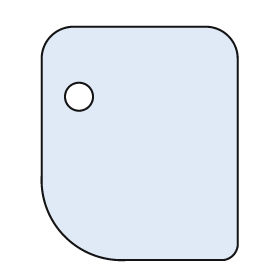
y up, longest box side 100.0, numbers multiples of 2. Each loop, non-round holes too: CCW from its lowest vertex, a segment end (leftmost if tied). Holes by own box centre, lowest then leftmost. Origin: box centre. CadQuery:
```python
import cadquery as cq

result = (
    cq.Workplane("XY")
    .moveTo(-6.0, -50.0)
    .lineTo(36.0, -50.0)
    .threePointArc((40.0, -48.0), (42.0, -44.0))
    .lineTo(42.0, 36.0)
    .threePointArc((38.0, 46.0), (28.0, 50.0))
    .lineTo(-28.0, 50.0)
    .threePointArc((-38.0, 46.0), (-42.0, 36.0))
    .lineTo(-42.0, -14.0)
    .threePointArc((-32.0, -40.0), (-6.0, -50.0))
    .close()
    .moveTo(-26.0, 20.0)
    .circle(6.0)
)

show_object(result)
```